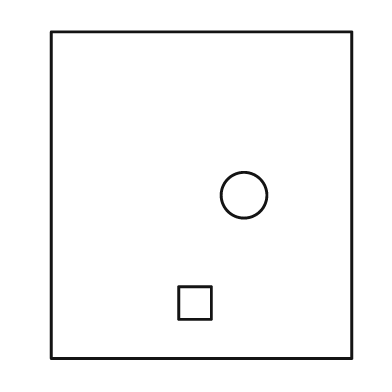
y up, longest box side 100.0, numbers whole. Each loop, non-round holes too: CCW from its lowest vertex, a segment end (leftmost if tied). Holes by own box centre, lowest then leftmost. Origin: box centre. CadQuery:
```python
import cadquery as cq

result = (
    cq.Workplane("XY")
    .moveTo(-46.0, -50.0)
    .lineTo(46.0, -50.0)
    .lineTo(46.0, 50.0)
    .lineTo(-46.0, 50.0)
    .close()
    .moveTo(-7.0, -38.0)
    .lineTo(3.0, -38.0)
    .lineTo(3.0, -28.0)
    .lineTo(-7.0, -28.0)
    .close()
    .moveTo(13.0, 0.0)
    .circle(7.0)
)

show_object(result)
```